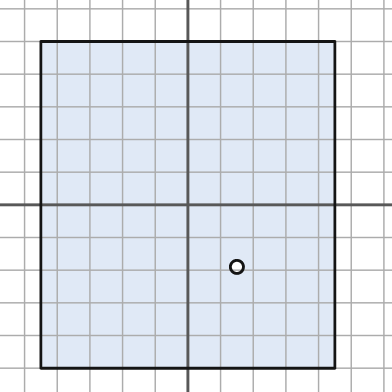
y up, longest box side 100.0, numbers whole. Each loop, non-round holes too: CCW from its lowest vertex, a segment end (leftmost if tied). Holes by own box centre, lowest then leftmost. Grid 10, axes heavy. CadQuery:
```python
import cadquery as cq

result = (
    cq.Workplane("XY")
    .moveTo(-45.0, -50.0)
    .lineTo(45.0, -50.0)
    .lineTo(45.0, 50.0)
    .lineTo(-45.0, 50.0)
    .close()
    .moveTo(15.0, -19.0)
    .circle(2.0)
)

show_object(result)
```